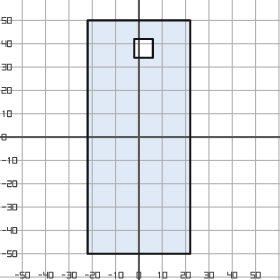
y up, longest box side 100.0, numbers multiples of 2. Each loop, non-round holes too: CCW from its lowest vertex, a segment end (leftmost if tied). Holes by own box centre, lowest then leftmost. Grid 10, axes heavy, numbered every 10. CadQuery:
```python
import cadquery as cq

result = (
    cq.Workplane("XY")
    .moveTo(-22.0, -50.0)
    .lineTo(22.0, -50.0)
    .lineTo(22.0, 50.0)
    .lineTo(-22.0, 50.0)
    .close()
    .moveTo(-2.0, 34.0)
    .lineTo(6.0, 34.0)
    .lineTo(6.0, 42.0)
    .lineTo(-2.0, 42.0)
    .close()
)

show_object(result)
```